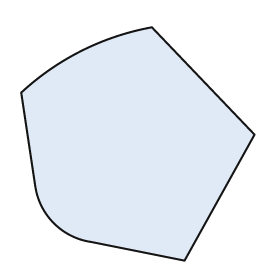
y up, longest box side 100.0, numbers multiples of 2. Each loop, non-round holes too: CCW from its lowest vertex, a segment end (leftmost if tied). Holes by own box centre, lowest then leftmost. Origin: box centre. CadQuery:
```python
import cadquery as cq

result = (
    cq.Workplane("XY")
    .moveTo(20.0, -50.0)
    .lineTo(50.0, 4.0)
    .lineTo(6.0, 50.0)
    .threePointArc((-24.0, 40.0), (-50.0, 22.0))
    .lineTo(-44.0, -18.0)
    .threePointArc((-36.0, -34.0), (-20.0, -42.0))
    .close()
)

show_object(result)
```